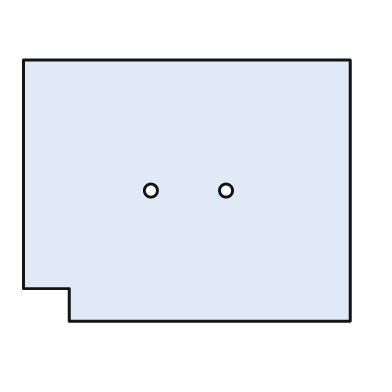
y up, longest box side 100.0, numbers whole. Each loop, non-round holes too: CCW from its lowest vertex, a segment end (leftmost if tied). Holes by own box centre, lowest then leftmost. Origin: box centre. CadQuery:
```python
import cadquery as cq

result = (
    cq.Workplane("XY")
    .moveTo(-36.0, -40.0)
    .lineTo(50.0, -40.0)
    .lineTo(50.0, 40.0)
    .lineTo(-50.0, 40.0)
    .lineTo(-50.0, -30.0)
    .lineTo(-36.0, -30.0)
    .close()
    .moveTo(-11.0, 0.0)
    .circle(2.0)
    .moveTo(12.0, 0.0)
    .circle(2.0)
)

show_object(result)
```